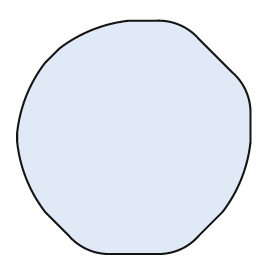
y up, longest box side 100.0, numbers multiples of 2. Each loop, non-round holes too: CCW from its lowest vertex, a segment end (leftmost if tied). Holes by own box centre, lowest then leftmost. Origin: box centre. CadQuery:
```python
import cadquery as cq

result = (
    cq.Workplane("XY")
    .moveTo(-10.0, -50.0)
    .lineTo(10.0, -50.0)
    .threePointArc((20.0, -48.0), (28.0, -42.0))
    .lineTo(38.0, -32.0)
    .threePointArc((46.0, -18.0), (50.0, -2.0))
    .lineTo(50.0, 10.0)
    .threePointArc((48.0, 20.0), (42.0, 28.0))
    .lineTo(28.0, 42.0)
    .threePointArc((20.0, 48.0), (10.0, 50.0))
    .lineTo(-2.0, 50.0)
    .threePointArc((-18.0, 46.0), (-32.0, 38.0))
    .lineTo(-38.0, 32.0)
    .threePointArc((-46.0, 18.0), (-50.0, 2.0))
    .lineTo(-50.0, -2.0)
    .threePointArc((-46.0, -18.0), (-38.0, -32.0))
    .lineTo(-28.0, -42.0)
    .threePointArc((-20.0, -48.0), (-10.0, -50.0))
    .close()
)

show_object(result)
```